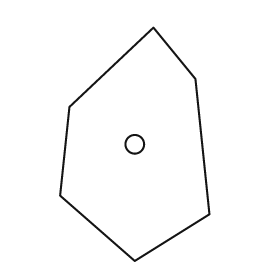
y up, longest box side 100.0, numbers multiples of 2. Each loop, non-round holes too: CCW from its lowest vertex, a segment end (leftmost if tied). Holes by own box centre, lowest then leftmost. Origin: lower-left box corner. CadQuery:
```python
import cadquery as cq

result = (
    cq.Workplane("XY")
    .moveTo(32.0, 0.0)
    .lineTo(64.0, 20.0)
    .lineTo(58.0, 78.0)
    .lineTo(40.0, 100.0)
    .lineTo(4.0, 66.0)
    .lineTo(0.0, 28.0)
    .close()
    .moveTo(32.0, 50.0)
    .circle(4.0)
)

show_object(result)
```